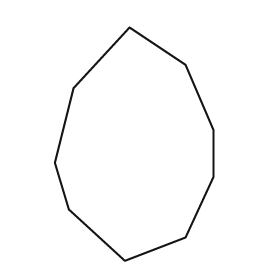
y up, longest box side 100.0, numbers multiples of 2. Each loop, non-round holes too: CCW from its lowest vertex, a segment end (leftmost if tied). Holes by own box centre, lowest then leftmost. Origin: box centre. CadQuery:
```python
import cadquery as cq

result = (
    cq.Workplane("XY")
    .moveTo(-4.0, -50.0)
    .lineTo(22.0, -40.0)
    .lineTo(34.0, -14.0)
    .lineTo(34.0, 6.0)
    .lineTo(22.0, 34.0)
    .lineTo(-2.0, 50.0)
    .lineTo(-26.0, 24.0)
    .lineTo(-34.0, -8.0)
    .lineTo(-28.0, -28.0)
    .close()
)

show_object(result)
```